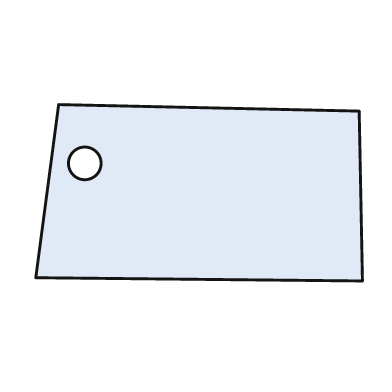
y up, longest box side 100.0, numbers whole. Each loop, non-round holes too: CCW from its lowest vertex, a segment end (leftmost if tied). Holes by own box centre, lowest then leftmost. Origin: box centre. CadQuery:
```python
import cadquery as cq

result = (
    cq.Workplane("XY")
    .moveTo(50.0, -27.0)
    .lineTo(49.0, 25.0)
    .lineTo(-43.0, 27.0)
    .lineTo(-50.0, -26.0)
    .close()
    .moveTo(-35.0, 9.0)
    .circle(5.0)
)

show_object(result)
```